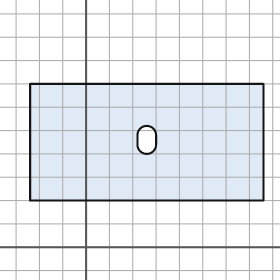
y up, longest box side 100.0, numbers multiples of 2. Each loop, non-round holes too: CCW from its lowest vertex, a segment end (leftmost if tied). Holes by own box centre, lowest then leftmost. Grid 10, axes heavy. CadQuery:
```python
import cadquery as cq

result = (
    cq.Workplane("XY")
    .moveTo(-24.0, 20.0)
    .lineTo(76.0, 20.0)
    .lineTo(76.0, 70.0)
    .lineTo(-24.0, 70.0)
    .close()
    .moveTo(22.0, 44.0)
    .threePointArc((26.0, 40.0), (30.0, 44.0))
    .lineTo(30.0, 48.0)
    .threePointArc((26.0, 52.0), (22.0, 48.0))
    .close()
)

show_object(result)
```